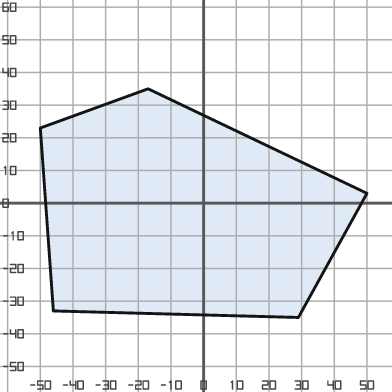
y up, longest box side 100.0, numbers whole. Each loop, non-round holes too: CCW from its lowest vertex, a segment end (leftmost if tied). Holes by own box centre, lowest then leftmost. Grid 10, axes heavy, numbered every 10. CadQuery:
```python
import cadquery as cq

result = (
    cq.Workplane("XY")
    .moveTo(29.0, -35.0)
    .lineTo(50.0, 3.0)
    .lineTo(-17.0, 35.0)
    .lineTo(-50.0, 23.0)
    .lineTo(-46.0, -33.0)
    .close()
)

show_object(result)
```